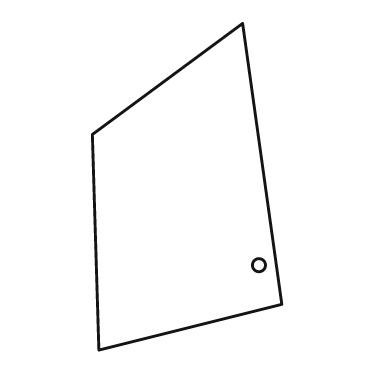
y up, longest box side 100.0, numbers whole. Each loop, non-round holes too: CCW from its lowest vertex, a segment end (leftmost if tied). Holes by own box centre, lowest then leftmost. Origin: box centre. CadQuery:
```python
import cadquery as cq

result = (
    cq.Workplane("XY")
    .moveTo(-27.0, -50.0)
    .lineTo(29.0, -36.0)
    .lineTo(17.0, 50.0)
    .lineTo(-29.0, 16.0)
    .close()
    .moveTo(22.0, -24.0)
    .circle(2.0)
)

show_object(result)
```